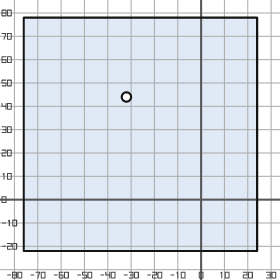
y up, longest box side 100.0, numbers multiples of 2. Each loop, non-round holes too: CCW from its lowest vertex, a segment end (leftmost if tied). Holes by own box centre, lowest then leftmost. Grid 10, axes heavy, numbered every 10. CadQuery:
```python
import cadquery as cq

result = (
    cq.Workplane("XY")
    .moveTo(-76.0, -22.0)
    .lineTo(24.0, -22.0)
    .lineTo(24.0, 78.0)
    .lineTo(-76.0, 78.0)
    .close()
    .moveTo(-32.0, 44.0)
    .circle(2.0)
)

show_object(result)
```